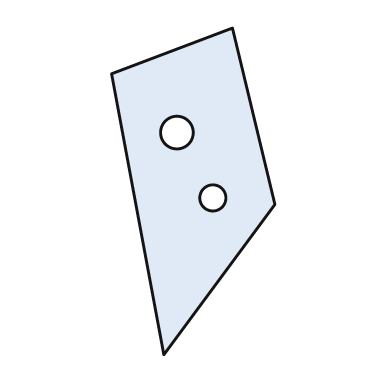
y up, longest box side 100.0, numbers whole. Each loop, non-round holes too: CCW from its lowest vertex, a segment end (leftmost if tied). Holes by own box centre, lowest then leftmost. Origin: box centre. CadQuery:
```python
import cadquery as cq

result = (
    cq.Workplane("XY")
    .moveTo(-9.0, -50.0)
    .lineTo(25.0, -4.0)
    .lineTo(12.0, 50.0)
    .lineTo(-25.0, 36.0)
    .close()
    .moveTo(6.0, -2.0)
    .circle(4.0)
    .moveTo(-5.0, 18.0)
    .circle(5.0)
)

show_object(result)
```